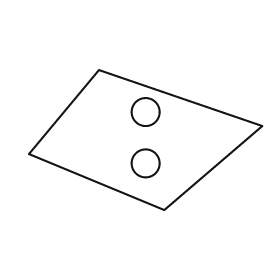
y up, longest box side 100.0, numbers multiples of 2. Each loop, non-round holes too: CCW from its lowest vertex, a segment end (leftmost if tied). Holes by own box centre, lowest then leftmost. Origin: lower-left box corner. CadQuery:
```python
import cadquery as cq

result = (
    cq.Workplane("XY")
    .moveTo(58.0, 0.0)
    .lineTo(100.0, 36.0)
    .lineTo(30.0, 60.0)
    .lineTo(0.0, 24.0)
    .close()
    .moveTo(50.0, 20.0)
    .circle(6.0)
    .moveTo(50.0, 42.0)
    .circle(6.0)
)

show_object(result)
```